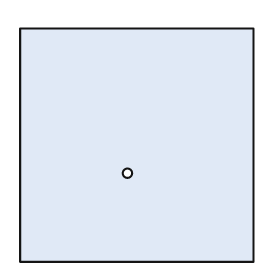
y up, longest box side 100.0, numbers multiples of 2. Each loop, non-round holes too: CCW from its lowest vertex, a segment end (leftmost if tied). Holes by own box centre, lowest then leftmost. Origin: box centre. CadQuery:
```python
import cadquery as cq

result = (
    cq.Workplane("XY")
    .moveTo(-50.0, -50.0)
    .lineTo(50.0, -50.0)
    .lineTo(50.0, 50.0)
    .lineTo(-50.0, 50.0)
    .close()
    .moveTo(-4.0, -12.0)
    .circle(2.0)
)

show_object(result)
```